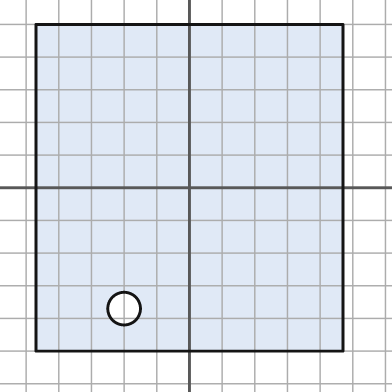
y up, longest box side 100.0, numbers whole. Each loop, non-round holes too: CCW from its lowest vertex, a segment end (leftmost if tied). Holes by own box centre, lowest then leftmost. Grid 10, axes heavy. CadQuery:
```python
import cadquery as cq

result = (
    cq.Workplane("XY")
    .moveTo(-47.0, -50.0)
    .lineTo(47.0, -50.0)
    .lineTo(47.0, 50.0)
    .lineTo(-47.0, 50.0)
    .close()
    .moveTo(-20.0, -37.0)
    .circle(5.0)
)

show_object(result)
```